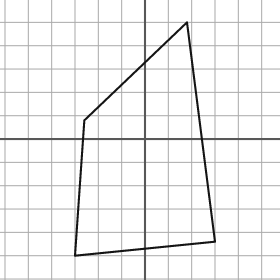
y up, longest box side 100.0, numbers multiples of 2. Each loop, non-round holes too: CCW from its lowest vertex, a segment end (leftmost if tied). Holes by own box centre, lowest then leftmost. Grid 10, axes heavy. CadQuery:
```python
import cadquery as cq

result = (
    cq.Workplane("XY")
    .moveTo(-30.0, -50.0)
    .lineTo(30.0, -44.0)
    .lineTo(18.0, 50.0)
    .lineTo(-26.0, 8.0)
    .close()
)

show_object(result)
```